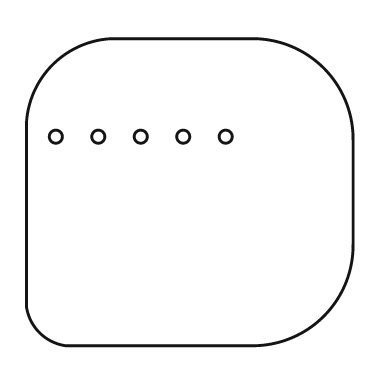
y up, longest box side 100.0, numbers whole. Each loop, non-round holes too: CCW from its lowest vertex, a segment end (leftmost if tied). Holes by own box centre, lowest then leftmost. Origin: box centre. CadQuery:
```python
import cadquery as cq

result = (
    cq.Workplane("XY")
    .moveTo(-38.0, -47.0)
    .lineTo(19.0, -47.0)
    .threePointArc((41.0, -38.0), (50.0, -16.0))
    .lineTo(50.0, 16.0)
    .threePointArc((41.0, 38.0), (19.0, 47.0))
    .lineTo(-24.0, 47.0)
    .threePointArc((-42.0, 39.0), (-50.0, 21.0))
    .lineTo(-50.0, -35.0)
    .threePointArc((-46.0, -43.0), (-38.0, -47.0))
    .close()
    .moveTo(-41.0, 17.0)
    .circle(2.0)
    .moveTo(-28.0, 17.0)
    .circle(2.0)
    .moveTo(-15.0, 17.0)
    .circle(2.0)
    .moveTo(-2.0, 17.0)
    .circle(2.0)
    .moveTo(11.0, 17.0)
    .circle(2.0)
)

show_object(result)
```